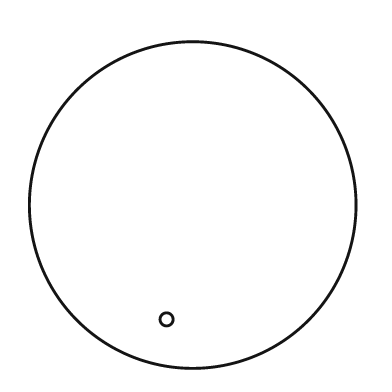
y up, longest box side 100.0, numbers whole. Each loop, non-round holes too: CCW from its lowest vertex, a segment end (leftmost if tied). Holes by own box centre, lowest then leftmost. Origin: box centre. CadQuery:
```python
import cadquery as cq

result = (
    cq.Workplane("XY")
    .moveTo(0.0, 0.0)
    .circle(50.0)
    .moveTo(-8.0, -35.0)
    .circle(2.0)
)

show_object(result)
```